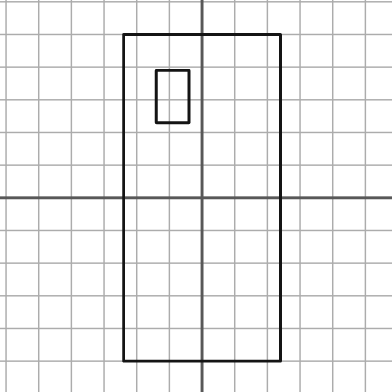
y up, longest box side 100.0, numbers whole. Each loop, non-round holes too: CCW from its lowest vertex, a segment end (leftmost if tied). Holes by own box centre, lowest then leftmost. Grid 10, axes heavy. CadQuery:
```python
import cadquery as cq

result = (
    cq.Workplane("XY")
    .moveTo(-24.0, -50.0)
    .lineTo(24.0, -50.0)
    .lineTo(24.0, 50.0)
    .lineTo(-24.0, 50.0)
    .close()
    .moveTo(-14.0, 23.0)
    .lineTo(-4.0, 23.0)
    .lineTo(-4.0, 39.0)
    .lineTo(-14.0, 39.0)
    .close()
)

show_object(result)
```